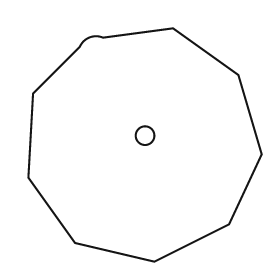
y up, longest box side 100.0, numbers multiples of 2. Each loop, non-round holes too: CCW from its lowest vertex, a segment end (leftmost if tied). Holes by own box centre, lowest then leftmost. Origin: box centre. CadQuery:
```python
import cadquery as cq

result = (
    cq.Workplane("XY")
    .moveTo(4.0, -50.0)
    .lineTo(36.0, -34.0)
    .lineTo(50.0, -4.0)
    .lineTo(40.0, 30.0)
    .lineTo(12.0, 50.0)
    .lineTo(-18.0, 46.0)
    .threePointArc((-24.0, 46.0), (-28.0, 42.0))
    .lineTo(-48.0, 22.0)
    .lineTo(-50.0, -14.0)
    .lineTo(-30.0, -42.0)
    .close()
    .moveTo(0.0, 4.0)
    .circle(4.0)
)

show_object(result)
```